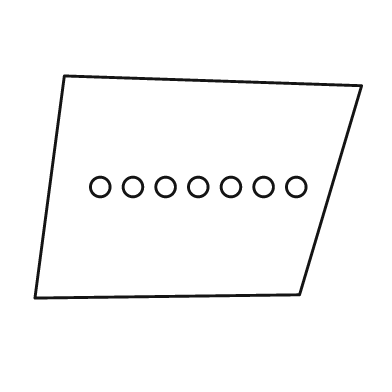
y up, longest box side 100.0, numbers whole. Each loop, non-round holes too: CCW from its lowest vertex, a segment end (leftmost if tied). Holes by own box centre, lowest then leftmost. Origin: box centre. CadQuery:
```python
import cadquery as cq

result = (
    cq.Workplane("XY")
    .moveTo(-50.0, -34.0)
    .lineTo(31.0, -33.0)
    .lineTo(50.0, 31.0)
    .lineTo(-41.0, 34.0)
    .close()
    .moveTo(-30.0, 0.0)
    .circle(3.0)
    .moveTo(-20.0, 0.0)
    .circle(3.0)
    .moveTo(-10.0, 0.0)
    .circle(3.0)
    .moveTo(0.0, 0.0)
    .circle(3.0)
    .moveTo(10.0, 0.0)
    .circle(3.0)
    .moveTo(20.0, 0.0)
    .circle(3.0)
    .moveTo(30.0, 0.0)
    .circle(3.0)
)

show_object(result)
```